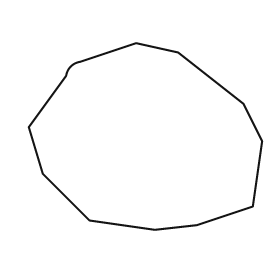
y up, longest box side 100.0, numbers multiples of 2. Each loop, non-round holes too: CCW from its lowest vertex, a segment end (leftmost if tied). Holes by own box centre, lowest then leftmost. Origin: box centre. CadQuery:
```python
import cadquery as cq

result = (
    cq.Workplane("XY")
    .moveTo(4.0, -40.0)
    .lineTo(22.0, -38.0)
    .lineTo(46.0, -30.0)
    .lineTo(50.0, -2.0)
    .lineTo(42.0, 14.0)
    .lineTo(14.0, 36.0)
    .lineTo(-4.0, 40.0)
    .lineTo(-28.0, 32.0)
    .threePointArc((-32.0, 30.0), (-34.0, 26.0))
    .lineTo(-50.0, 4.0)
    .lineTo(-44.0, -16.0)
    .lineTo(-24.0, -36.0)
    .close()
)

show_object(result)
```